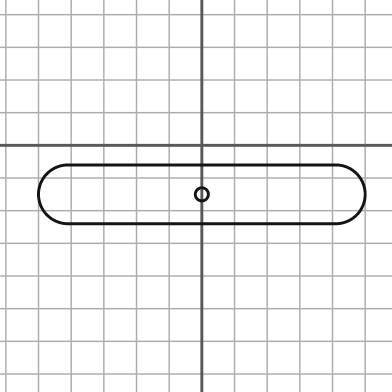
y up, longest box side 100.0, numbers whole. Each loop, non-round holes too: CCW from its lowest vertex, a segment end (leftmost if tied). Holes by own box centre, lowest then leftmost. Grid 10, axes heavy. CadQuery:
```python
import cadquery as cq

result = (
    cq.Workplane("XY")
    .moveTo(-41.0, -24.0)
    .lineTo(41.0, -24.0)
    .threePointArc((50.0, -15.0), (41.0, -6.0))
    .lineTo(-41.0, -6.0)
    .threePointArc((-50.0, -15.0), (-41.0, -24.0))
    .close()
    .moveTo(0.0, -15.0)
    .circle(2.0)
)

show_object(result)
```